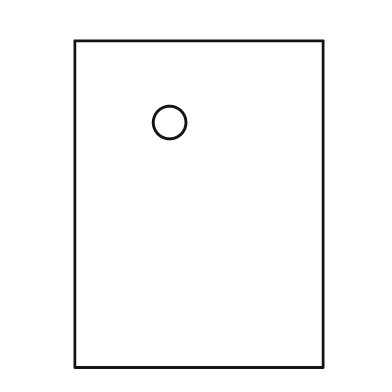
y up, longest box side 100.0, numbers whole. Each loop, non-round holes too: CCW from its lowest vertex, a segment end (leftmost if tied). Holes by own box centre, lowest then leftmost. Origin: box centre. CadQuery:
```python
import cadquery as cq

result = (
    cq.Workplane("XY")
    .moveTo(-38.0, -50.0)
    .lineTo(38.0, -50.0)
    .lineTo(38.0, 50.0)
    .lineTo(-38.0, 50.0)
    .close()
    .moveTo(-9.0, 25.0)
    .circle(5.0)
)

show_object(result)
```